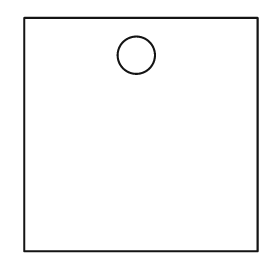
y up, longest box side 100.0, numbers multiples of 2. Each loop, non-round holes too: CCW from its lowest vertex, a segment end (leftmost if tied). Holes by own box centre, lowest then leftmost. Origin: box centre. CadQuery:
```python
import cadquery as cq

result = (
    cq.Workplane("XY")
    .moveTo(-50.0, -50.0)
    .lineTo(50.0, -50.0)
    .lineTo(50.0, 50.0)
    .lineTo(-50.0, 50.0)
    .close()
    .moveTo(-2.0, 34.0)
    .circle(8.0)
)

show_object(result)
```